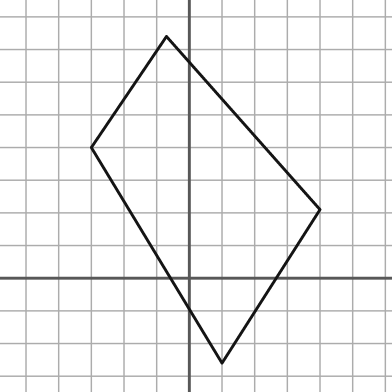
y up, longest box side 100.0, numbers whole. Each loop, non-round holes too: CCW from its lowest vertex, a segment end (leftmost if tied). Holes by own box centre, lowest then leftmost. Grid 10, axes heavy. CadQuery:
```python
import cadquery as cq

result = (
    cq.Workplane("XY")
    .moveTo(10.0, -26.0)
    .lineTo(40.0, 21.0)
    .lineTo(-7.0, 74.0)
    .lineTo(-30.0, 40.0)
    .close()
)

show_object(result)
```